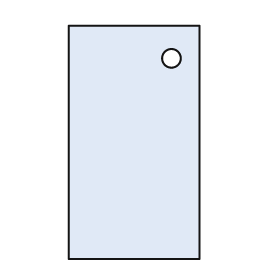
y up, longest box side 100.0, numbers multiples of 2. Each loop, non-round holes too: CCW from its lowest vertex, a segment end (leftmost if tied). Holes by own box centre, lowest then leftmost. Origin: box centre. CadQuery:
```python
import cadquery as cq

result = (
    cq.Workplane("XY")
    .moveTo(-28.0, -50.0)
    .lineTo(28.0, -50.0)
    .lineTo(28.0, 50.0)
    .lineTo(-28.0, 50.0)
    .close()
    .moveTo(16.0, 36.0)
    .circle(4.0)
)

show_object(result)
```